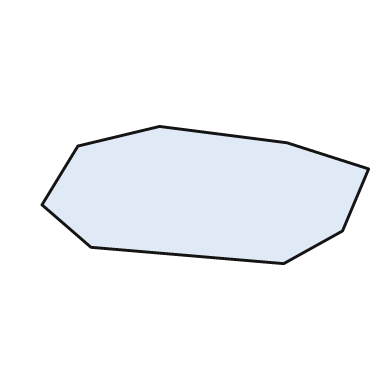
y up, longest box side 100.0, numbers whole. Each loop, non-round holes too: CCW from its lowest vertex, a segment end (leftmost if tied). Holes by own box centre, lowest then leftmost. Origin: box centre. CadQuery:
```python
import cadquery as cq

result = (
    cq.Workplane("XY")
    .moveTo(24.0, -21.0)
    .lineTo(42.0, -11.0)
    .lineTo(50.0, 8.0)
    .lineTo(25.0, 16.0)
    .lineTo(-14.0, 21.0)
    .lineTo(-39.0, 15.0)
    .lineTo(-50.0, -3.0)
    .lineTo(-35.0, -16.0)
    .close()
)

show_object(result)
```